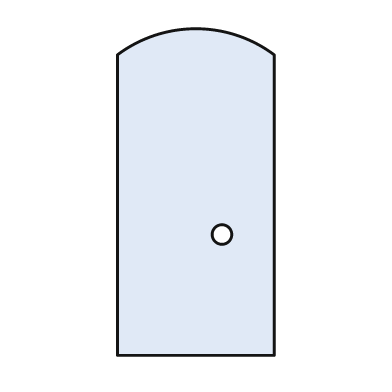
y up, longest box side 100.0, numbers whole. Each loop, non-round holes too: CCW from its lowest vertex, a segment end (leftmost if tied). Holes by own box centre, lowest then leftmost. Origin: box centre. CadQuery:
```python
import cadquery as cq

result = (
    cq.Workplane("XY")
    .moveTo(-24.0, -50.0)
    .lineTo(24.0, -50.0)
    .lineTo(24.0, 42.0)
    .threePointArc((0.0, 50.0), (-24.0, 42.0))
    .close()
    .moveTo(8.0, -13.0)
    .circle(3.0)
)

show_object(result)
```